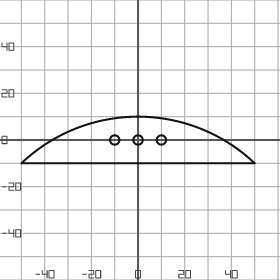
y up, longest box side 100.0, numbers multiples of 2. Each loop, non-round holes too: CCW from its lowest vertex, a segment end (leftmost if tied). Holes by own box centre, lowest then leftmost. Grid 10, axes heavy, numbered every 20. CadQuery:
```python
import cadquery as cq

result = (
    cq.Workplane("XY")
    .moveTo(-50.0, -10.0)
    .lineTo(50.0, -10.0)
    .threePointArc((0.0, 10.0), (-50.0, -10.0))
    .close()
    .moveTo(-10.0, 0.0)
    .circle(2.0)
    .moveTo(0.0, 0.0)
    .circle(2.0)
    .moveTo(10.0, 0.0)
    .circle(2.0)
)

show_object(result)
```